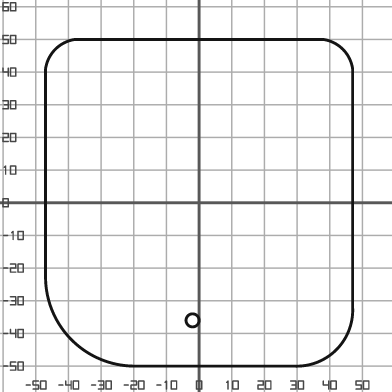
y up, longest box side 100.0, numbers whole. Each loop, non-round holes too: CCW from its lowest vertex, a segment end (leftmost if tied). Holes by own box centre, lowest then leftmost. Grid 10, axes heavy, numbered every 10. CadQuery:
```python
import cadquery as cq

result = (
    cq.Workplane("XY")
    .moveTo(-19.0, -50.0)
    .lineTo(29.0, -50.0)
    .threePointArc((42.0, -45.0), (47.0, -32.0))
    .lineTo(47.0, 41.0)
    .threePointArc((44.0, 47.0), (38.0, 50.0))
    .lineTo(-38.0, 50.0)
    .threePointArc((-44.0, 47.0), (-47.0, 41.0))
    .lineTo(-47.0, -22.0)
    .threePointArc((-39.0, -42.0), (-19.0, -50.0))
    .close()
    .moveTo(-2.0, -36.0)
    .circle(2.0)
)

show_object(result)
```